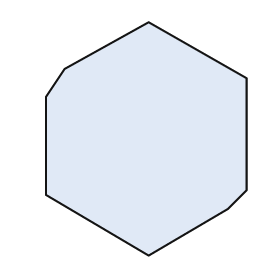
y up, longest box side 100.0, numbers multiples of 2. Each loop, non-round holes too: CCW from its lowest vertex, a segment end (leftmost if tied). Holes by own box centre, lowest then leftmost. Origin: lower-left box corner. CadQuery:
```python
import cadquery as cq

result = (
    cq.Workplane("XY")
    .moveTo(44.0, 0.0)
    .lineTo(78.0, 20.0)
    .lineTo(86.0, 28.0)
    .lineTo(86.0, 76.0)
    .lineTo(44.0, 100.0)
    .lineTo(8.0, 80.0)
    .lineTo(0.0, 68.0)
    .lineTo(0.0, 26.0)
    .close()
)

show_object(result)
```